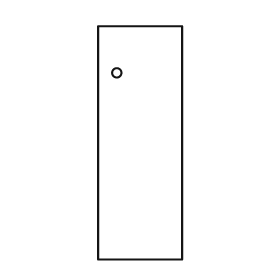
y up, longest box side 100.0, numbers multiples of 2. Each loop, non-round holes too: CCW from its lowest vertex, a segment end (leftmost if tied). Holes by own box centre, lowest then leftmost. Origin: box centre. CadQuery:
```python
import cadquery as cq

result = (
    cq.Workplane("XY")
    .moveTo(-18.0, -50.0)
    .lineTo(18.0, -50.0)
    .lineTo(18.0, 50.0)
    .lineTo(-18.0, 50.0)
    .close()
    .moveTo(-10.0, 30.0)
    .circle(2.0)
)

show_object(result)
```